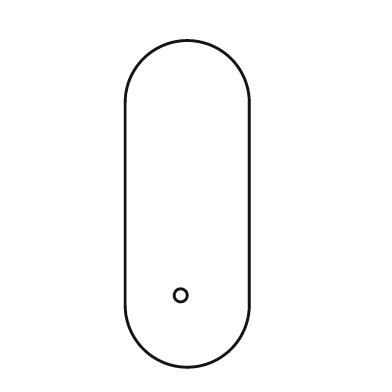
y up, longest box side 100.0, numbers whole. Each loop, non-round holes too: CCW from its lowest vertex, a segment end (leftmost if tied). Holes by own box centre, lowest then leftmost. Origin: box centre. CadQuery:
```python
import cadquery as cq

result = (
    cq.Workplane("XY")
    .moveTo(-19.0, -31.0)
    .threePointArc((0.0, -50.0), (19.0, -31.0))
    .lineTo(19.0, 31.0)
    .threePointArc((0.0, 50.0), (-19.0, 31.0))
    .close()
    .moveTo(-2.0, -28.0)
    .circle(2.0)
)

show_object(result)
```